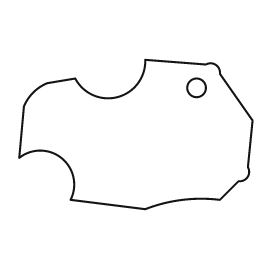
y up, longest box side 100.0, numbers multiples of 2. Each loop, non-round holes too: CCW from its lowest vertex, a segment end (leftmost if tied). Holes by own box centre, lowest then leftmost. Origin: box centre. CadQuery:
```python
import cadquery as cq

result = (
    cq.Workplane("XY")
    .moveTo(4.0, -32.0)
    .threePointArc((20.0, -28.0), (36.0, -28.0))
    .lineTo(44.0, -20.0)
    .threePointArc((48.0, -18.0), (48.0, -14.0))
    .lineTo(50.0, 6.0)
    .lineTo(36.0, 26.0)
    .threePointArc((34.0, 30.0), (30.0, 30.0))
    .lineTo(4.0, 32.0)
    .threePointArc((-8.0, 16.0), (-26.0, 24.0))
    .lineTo(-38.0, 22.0)
    .threePointArc((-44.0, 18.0), (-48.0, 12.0))
    .lineTo(-50.0, -10.0)
    .threePointArc((-32.0, -10.0), (-28.0, -28.0))
    .close()
    .moveTo(26.0, 20.0)
    .circle(4.0)
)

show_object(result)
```